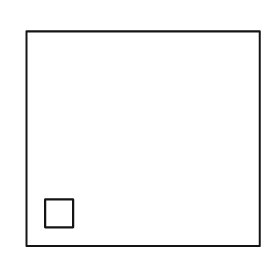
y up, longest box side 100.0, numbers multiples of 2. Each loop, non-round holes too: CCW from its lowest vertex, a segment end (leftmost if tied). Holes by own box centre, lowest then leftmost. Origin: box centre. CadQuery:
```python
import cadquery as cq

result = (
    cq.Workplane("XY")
    .moveTo(-50.0, -46.0)
    .lineTo(50.0, -46.0)
    .lineTo(50.0, 46.0)
    .lineTo(-50.0, 46.0)
    .close()
    .moveTo(-42.0, -38.0)
    .lineTo(-30.0, -38.0)
    .lineTo(-30.0, -26.0)
    .lineTo(-42.0, -26.0)
    .close()
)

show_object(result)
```